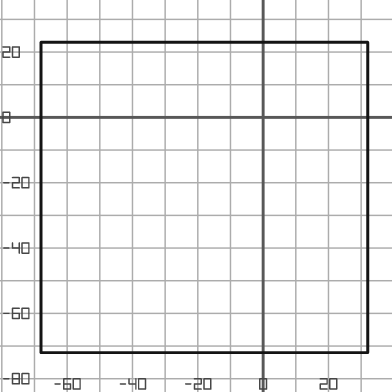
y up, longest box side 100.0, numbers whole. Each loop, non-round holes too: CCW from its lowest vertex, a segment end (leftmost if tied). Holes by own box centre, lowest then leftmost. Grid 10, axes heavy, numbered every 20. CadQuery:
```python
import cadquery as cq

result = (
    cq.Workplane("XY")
    .moveTo(-68.0, -72.0)
    .lineTo(32.0, -72.0)
    .lineTo(32.0, 23.0)
    .lineTo(-68.0, 23.0)
    .close()
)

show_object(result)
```